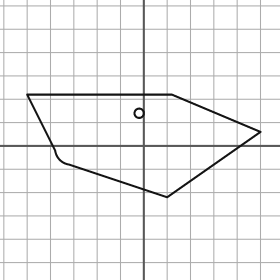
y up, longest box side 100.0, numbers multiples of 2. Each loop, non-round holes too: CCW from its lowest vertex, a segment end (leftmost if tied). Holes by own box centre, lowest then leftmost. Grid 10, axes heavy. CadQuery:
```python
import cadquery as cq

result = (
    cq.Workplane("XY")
    .moveTo(10.0, -22.0)
    .lineTo(50.0, 6.0)
    .lineTo(12.0, 22.0)
    .lineTo(-50.0, 22.0)
    .lineTo(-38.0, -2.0)
    .threePointArc((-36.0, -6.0), (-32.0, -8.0))
    .close()
    .moveTo(-2.0, 14.0)
    .circle(2.0)
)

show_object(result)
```